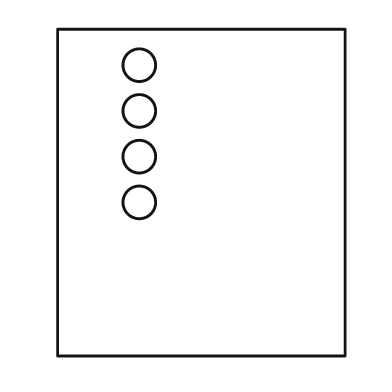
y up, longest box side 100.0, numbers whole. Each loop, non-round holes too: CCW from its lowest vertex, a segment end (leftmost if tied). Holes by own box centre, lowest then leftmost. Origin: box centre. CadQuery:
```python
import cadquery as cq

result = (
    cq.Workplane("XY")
    .moveTo(-44.0, -50.0)
    .lineTo(44.0, -50.0)
    .lineTo(44.0, 50.0)
    .lineTo(-44.0, 50.0)
    .close()
    .moveTo(-19.0, -3.0)
    .circle(5.0)
    .moveTo(-19.0, 11.0)
    .circle(5.0)
    .moveTo(-19.0, 25.0)
    .circle(5.0)
    .moveTo(-19.0, 39.0)
    .circle(5.0)
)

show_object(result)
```